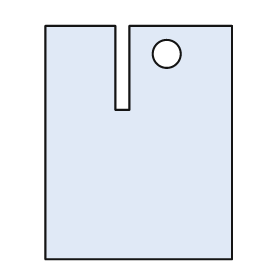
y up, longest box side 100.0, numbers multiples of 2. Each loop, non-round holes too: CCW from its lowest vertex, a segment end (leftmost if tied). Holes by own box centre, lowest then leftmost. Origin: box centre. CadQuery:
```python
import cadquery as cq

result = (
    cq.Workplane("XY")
    .moveTo(-40.0, -50.0)
    .lineTo(40.0, -50.0)
    .lineTo(40.0, 50.0)
    .lineTo(-4.0, 50.0)
    .lineTo(-4.0, 14.0)
    .lineTo(-10.0, 14.0)
    .lineTo(-10.0, 50.0)
    .lineTo(-40.0, 50.0)
    .close()
    .moveTo(12.0, 38.0)
    .circle(6.0)
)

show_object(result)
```